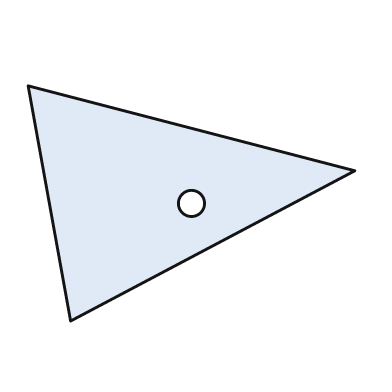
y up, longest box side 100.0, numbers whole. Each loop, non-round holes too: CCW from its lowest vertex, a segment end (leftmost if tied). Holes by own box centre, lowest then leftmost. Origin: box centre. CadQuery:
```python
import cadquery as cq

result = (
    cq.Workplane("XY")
    .moveTo(-37.0, -36.0)
    .lineTo(50.0, 10.0)
    .lineTo(-50.0, 36.0)
    .close()
    .moveTo(0.0, 0.0)
    .circle(4.0)
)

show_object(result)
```